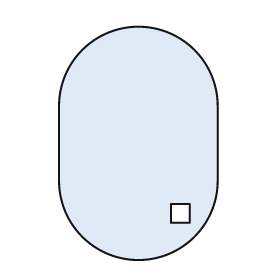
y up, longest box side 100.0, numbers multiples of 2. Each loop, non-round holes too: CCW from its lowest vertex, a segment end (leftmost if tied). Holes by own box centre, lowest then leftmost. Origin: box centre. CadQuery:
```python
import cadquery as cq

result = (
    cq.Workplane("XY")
    .moveTo(-34.0, -16.0)
    .threePointArc((0.0, -50.0), (34.0, -16.0))
    .lineTo(34.0, 16.0)
    .threePointArc((0.0, 50.0), (-34.0, 16.0))
    .close()
    .moveTo(14.0, -34.0)
    .lineTo(22.0, -34.0)
    .lineTo(22.0, -26.0)
    .lineTo(14.0, -26.0)
    .close()
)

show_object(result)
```